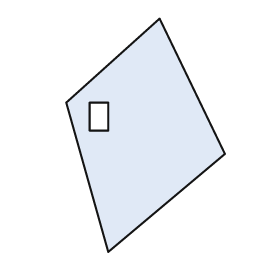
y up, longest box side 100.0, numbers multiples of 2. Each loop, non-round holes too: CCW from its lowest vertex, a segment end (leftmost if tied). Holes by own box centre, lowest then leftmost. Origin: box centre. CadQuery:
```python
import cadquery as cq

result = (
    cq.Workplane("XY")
    .moveTo(-16.0, -50.0)
    .lineTo(34.0, -8.0)
    .lineTo(6.0, 50.0)
    .lineTo(-34.0, 14.0)
    .close()
    .moveTo(-24.0, 2.0)
    .lineTo(-16.0, 2.0)
    .lineTo(-16.0, 14.0)
    .lineTo(-24.0, 14.0)
    .close()
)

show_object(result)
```